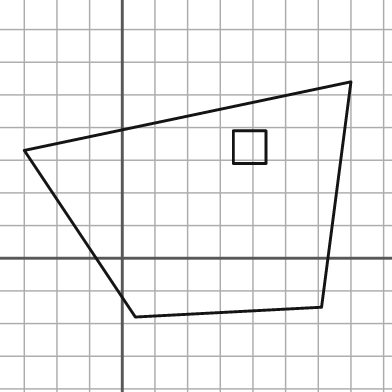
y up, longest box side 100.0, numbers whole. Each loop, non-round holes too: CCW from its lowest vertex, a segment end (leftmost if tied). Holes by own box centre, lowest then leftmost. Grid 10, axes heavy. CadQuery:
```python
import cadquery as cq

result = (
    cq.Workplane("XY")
    .moveTo(4.0, -18.0)
    .lineTo(61.0, -15.0)
    .lineTo(70.0, 54.0)
    .lineTo(-30.0, 33.0)
    .close()
    .moveTo(34.0, 29.0)
    .lineTo(44.0, 29.0)
    .lineTo(44.0, 39.0)
    .lineTo(34.0, 39.0)
    .close()
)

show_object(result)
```